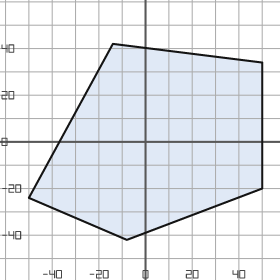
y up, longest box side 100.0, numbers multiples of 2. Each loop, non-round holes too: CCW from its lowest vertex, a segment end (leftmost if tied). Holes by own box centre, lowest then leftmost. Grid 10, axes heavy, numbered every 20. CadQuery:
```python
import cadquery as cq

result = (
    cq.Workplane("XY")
    .moveTo(-8.0, -42.0)
    .lineTo(50.0, -20.0)
    .lineTo(50.0, 34.0)
    .lineTo(-14.0, 42.0)
    .lineTo(-50.0, -24.0)
    .close()
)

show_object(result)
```